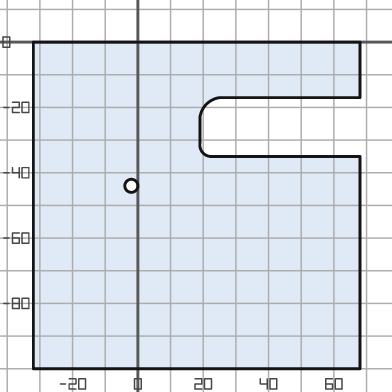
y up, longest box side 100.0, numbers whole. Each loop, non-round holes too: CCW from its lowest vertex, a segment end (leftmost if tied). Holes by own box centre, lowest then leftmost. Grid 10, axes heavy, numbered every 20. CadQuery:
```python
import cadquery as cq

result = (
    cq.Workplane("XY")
    .moveTo(-32.0, -100.0)
    .lineTo(68.0, -100.0)
    .lineTo(68.0, -35.0)
    .lineTo(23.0, -35.0)
    .threePointArc((20.0, -34.0), (19.0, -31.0))
    .lineTo(19.0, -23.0)
    .threePointArc((21.0, -19.0), (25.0, -17.0))
    .lineTo(68.0, -17.0)
    .lineTo(68.0, 0.0)
    .lineTo(-32.0, 0.0)
    .close()
    .moveTo(-2.0, -44.0)
    .circle(2.0)
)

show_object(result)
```